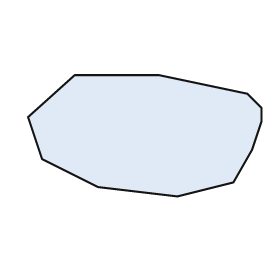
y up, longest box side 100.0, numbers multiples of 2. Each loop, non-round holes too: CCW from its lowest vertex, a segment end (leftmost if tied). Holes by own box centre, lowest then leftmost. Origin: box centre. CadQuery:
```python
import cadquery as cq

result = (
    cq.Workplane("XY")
    .moveTo(14.0, -26.0)
    .lineTo(38.0, -20.0)
    .lineTo(46.0, -6.0)
    .lineTo(50.0, 6.0)
    .lineTo(50.0, 12.0)
    .lineTo(44.0, 18.0)
    .lineTo(6.0, 26.0)
    .lineTo(-30.0, 26.0)
    .lineTo(-50.0, 8.0)
    .lineTo(-44.0, -10.0)
    .lineTo(-20.0, -22.0)
    .close()
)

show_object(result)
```